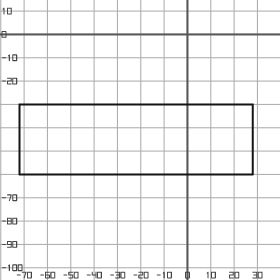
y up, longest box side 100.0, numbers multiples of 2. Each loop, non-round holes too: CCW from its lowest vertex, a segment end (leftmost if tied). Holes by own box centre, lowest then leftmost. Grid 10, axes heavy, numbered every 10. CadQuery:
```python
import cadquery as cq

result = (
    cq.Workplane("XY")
    .moveTo(-72.0, -60.0)
    .lineTo(28.0, -60.0)
    .lineTo(28.0, -30.0)
    .lineTo(-72.0, -30.0)
    .close()
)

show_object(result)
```